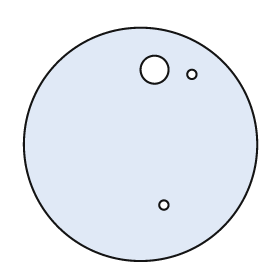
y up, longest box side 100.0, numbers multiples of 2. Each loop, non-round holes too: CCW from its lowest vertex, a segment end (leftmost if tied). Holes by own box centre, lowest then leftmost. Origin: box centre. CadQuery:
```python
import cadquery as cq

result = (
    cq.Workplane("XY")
    .moveTo(0.0, 0.0)
    .circle(50.0)
    .moveTo(10.0, -26.0)
    .circle(2.0)
    .moveTo(22.0, 30.0)
    .circle(2.0)
    .moveTo(6.0, 32.0)
    .circle(6.0)
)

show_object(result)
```